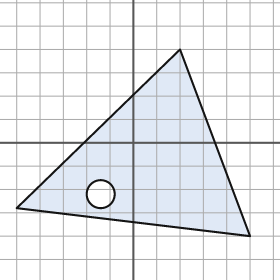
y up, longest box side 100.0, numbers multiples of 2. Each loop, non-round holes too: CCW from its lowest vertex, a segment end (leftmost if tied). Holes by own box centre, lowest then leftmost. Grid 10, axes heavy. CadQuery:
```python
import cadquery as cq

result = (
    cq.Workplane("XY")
    .moveTo(50.0, -40.0)
    .lineTo(20.0, 40.0)
    .lineTo(-50.0, -28.0)
    .close()
    .moveTo(-14.0, -22.0)
    .circle(6.0)
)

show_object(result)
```